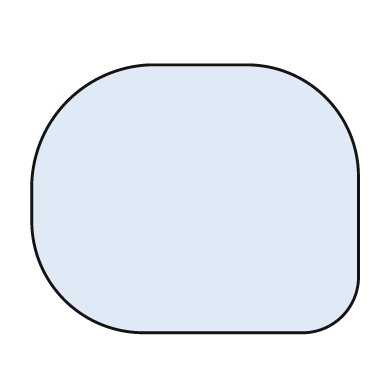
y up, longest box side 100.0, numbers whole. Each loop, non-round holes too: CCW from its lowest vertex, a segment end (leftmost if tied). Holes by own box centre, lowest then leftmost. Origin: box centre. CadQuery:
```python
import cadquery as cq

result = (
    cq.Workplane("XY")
    .moveTo(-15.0, -41.0)
    .lineTo(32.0, -41.0)
    .threePointArc((45.0, -36.0), (50.0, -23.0))
    .lineTo(50.0, 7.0)
    .threePointArc((40.0, 31.0), (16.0, 41.0))
    .lineTo(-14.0, 41.0)
    .threePointArc((-39.0, 30.0), (-50.0, 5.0))
    .lineTo(-50.0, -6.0)
    .threePointArc((-40.0, -31.0), (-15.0, -41.0))
    .close()
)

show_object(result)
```